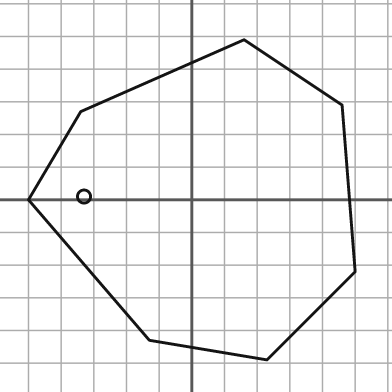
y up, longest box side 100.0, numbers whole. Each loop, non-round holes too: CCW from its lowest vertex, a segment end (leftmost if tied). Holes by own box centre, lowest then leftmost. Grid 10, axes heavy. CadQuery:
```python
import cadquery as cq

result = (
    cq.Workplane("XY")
    .moveTo(23.0, -49.0)
    .lineTo(50.0, -22.0)
    .lineTo(46.0, 29.0)
    .lineTo(16.0, 49.0)
    .lineTo(-34.0, 27.0)
    .lineTo(-50.0, 0.0)
    .lineTo(-13.0, -43.0)
    .close()
    .moveTo(-33.0, 1.0)
    .circle(2.0)
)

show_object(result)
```